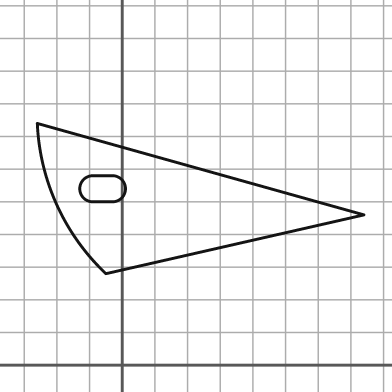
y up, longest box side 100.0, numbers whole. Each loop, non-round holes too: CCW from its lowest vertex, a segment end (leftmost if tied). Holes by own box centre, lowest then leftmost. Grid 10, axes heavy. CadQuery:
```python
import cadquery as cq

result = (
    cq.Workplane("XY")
    .moveTo(-5.0, 28.0)
    .lineTo(74.0, 46.0)
    .lineTo(-26.0, 74.0)
    .threePointArc((-20.0, 49.0), (-5.0, 28.0))
    .close()
    .moveTo(-9.0, 50.0)
    .lineTo(-3.0, 50.0)
    .threePointArc((1.0, 54.0), (-3.0, 58.0))
    .lineTo(-9.0, 58.0)
    .threePointArc((-13.0, 54.0), (-9.0, 50.0))
    .close()
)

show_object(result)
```